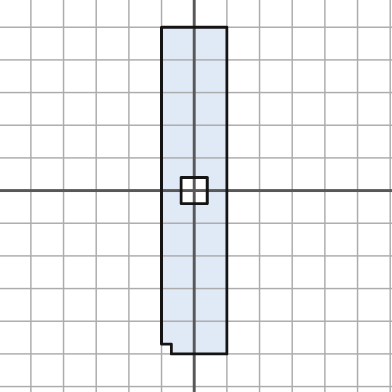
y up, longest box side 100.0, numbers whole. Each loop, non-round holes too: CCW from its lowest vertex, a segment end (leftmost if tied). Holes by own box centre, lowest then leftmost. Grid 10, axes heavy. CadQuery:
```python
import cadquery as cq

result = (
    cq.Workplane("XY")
    .moveTo(-7.0, -50.0)
    .lineTo(10.0, -50.0)
    .lineTo(10.0, 50.0)
    .lineTo(-10.0, 50.0)
    .lineTo(-10.0, -47.0)
    .lineTo(-7.0, -47.0)
    .close()
    .moveTo(-4.0, -4.0)
    .lineTo(4.0, -4.0)
    .lineTo(4.0, 4.0)
    .lineTo(-4.0, 4.0)
    .close()
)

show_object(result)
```